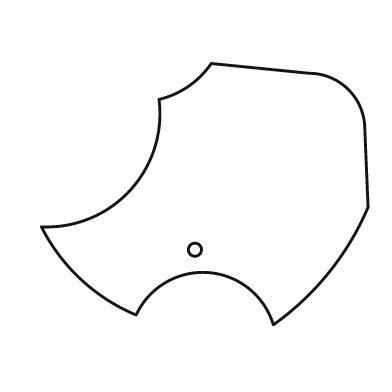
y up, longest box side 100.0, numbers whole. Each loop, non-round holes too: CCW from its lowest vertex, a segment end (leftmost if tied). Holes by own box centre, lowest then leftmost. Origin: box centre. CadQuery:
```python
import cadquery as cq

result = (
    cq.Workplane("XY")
    .moveTo(21.0, -40.0)
    .threePointArc((38.0, -24.0), (50.0, -4.0))
    .lineTo(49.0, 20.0)
    .threePointArc((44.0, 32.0), (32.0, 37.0))
    .lineTo(2.0, 40.0)
    .threePointArc((-5.0, 33.0), (-14.0, 29.0))
    .threePointArc((-23.0, 1.0), (-50.0, -10.0))
    .threePointArc((-38.0, -26.0), (-21.0, -37.0))
    .threePointArc((1.0, -24.0), (21.0, -40.0))
    .close()
    .moveTo(-3.0, -17.0)
    .circle(2.0)
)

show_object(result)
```